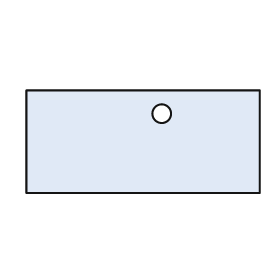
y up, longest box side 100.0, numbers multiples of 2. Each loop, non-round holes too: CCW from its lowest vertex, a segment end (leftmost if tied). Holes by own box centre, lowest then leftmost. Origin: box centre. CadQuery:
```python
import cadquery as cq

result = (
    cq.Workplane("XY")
    .moveTo(-50.0, -22.0)
    .lineTo(50.0, -22.0)
    .lineTo(50.0, 22.0)
    .lineTo(-50.0, 22.0)
    .close()
    .moveTo(8.0, 12.0)
    .circle(4.0)
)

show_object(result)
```